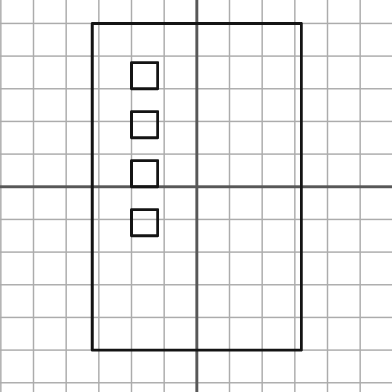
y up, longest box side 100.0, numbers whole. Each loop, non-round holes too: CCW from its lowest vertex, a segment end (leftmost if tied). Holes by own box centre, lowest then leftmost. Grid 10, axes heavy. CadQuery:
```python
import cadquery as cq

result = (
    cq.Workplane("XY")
    .moveTo(-32.0, -50.0)
    .lineTo(32.0, -50.0)
    .lineTo(32.0, 50.0)
    .lineTo(-32.0, 50.0)
    .close()
    .moveTo(-20.0, -15.0)
    .lineTo(-12.0, -15.0)
    .lineTo(-12.0, -7.0)
    .lineTo(-20.0, -7.0)
    .close()
    .moveTo(-20.0, 0.0)
    .lineTo(-12.0, 0.0)
    .lineTo(-12.0, 8.0)
    .lineTo(-20.0, 8.0)
    .close()
    .moveTo(-20.0, 15.0)
    .lineTo(-12.0, 15.0)
    .lineTo(-12.0, 23.0)
    .lineTo(-20.0, 23.0)
    .close()
    .moveTo(-20.0, 30.0)
    .lineTo(-12.0, 30.0)
    .lineTo(-12.0, 38.0)
    .lineTo(-20.0, 38.0)
    .close()
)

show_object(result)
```